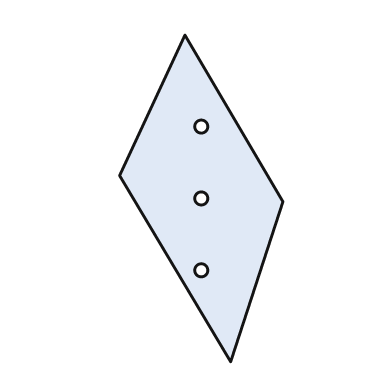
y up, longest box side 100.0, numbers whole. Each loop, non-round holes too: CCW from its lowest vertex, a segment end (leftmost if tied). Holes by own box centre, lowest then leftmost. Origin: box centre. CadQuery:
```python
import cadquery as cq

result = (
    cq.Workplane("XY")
    .moveTo(9.0, -50.0)
    .lineTo(25.0, -1.0)
    .lineTo(-5.0, 50.0)
    .lineTo(-25.0, 7.0)
    .close()
    .moveTo(0.0, -22.0)
    .circle(2.0)
    .moveTo(0.0, 0.0)
    .circle(2.0)
    .moveTo(0.0, 22.0)
    .circle(2.0)
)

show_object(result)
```